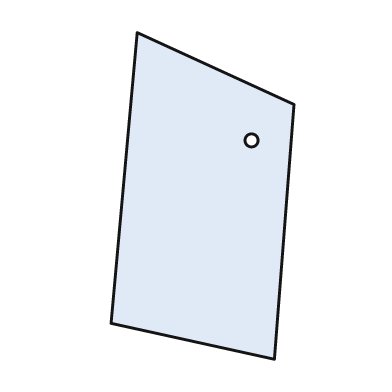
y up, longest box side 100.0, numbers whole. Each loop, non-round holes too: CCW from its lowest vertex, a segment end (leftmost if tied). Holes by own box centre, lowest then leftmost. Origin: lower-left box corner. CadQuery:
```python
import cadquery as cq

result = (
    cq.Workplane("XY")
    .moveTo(50.0, 0.0)
    .lineTo(56.0, 78.0)
    .lineTo(8.0, 100.0)
    .lineTo(0.0, 11.0)
    .close()
    .moveTo(43.0, 67.0)
    .circle(2.0)
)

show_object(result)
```